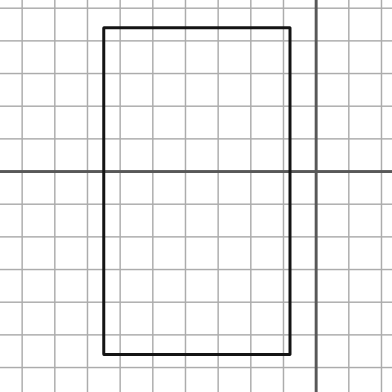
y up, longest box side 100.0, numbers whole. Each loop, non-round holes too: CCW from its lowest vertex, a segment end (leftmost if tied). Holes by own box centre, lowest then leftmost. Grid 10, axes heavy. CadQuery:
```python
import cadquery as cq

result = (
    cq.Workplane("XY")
    .moveTo(-65.0, -56.0)
    .lineTo(-8.0, -56.0)
    .lineTo(-8.0, 44.0)
    .lineTo(-65.0, 44.0)
    .close()
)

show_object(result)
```